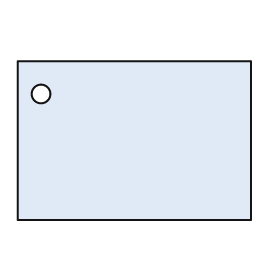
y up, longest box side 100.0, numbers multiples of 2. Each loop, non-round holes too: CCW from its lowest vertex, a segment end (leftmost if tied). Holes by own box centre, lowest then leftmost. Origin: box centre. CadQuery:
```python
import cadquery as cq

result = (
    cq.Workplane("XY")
    .moveTo(-50.0, -34.0)
    .lineTo(50.0, -34.0)
    .lineTo(50.0, 34.0)
    .lineTo(-50.0, 34.0)
    .close()
    .moveTo(-40.0, 20.0)
    .circle(4.0)
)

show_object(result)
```